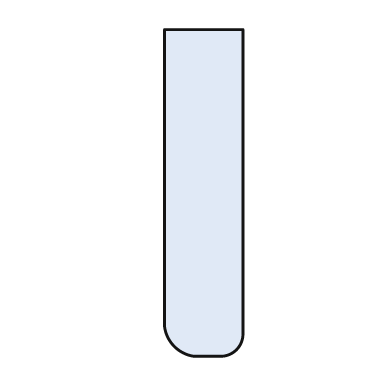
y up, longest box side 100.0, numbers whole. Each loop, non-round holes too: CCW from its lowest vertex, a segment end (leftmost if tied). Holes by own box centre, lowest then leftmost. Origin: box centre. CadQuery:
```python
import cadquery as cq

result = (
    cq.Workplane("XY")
    .moveTo(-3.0, -50.0)
    .lineTo(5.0, -50.0)
    .threePointArc((10.0, -48.0), (12.0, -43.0))
    .lineTo(12.0, 50.0)
    .lineTo(-12.0, 50.0)
    .lineTo(-12.0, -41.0)
    .threePointArc((-9.0, -47.0), (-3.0, -50.0))
    .close()
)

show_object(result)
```